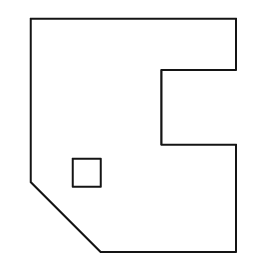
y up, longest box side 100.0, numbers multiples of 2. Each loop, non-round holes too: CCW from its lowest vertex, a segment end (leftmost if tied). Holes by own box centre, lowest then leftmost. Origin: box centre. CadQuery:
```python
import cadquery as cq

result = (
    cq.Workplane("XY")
    .moveTo(-14.0, -50.0)
    .lineTo(44.0, -50.0)
    .lineTo(44.0, -4.0)
    .lineTo(12.0, -4.0)
    .lineTo(12.0, 28.0)
    .lineTo(44.0, 28.0)
    .lineTo(44.0, 50.0)
    .lineTo(-44.0, 50.0)
    .lineTo(-44.0, -20.0)
    .close()
    .moveTo(-26.0, -22.0)
    .lineTo(-14.0, -22.0)
    .lineTo(-14.0, -10.0)
    .lineTo(-26.0, -10.0)
    .close()
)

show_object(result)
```